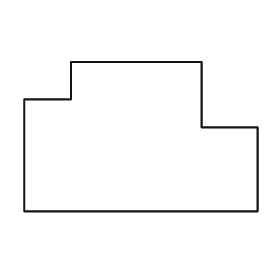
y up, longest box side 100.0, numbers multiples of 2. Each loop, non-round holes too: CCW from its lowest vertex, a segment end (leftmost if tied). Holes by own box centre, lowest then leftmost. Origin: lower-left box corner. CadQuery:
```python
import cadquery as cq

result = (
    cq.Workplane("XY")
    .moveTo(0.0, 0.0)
    .lineTo(100.0, 0.0)
    .lineTo(100.0, 36.0)
    .lineTo(76.0, 36.0)
    .lineTo(76.0, 64.0)
    .lineTo(20.0, 64.0)
    .lineTo(20.0, 48.0)
    .lineTo(0.0, 48.0)
    .close()
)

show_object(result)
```